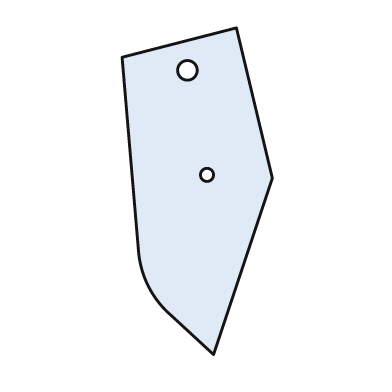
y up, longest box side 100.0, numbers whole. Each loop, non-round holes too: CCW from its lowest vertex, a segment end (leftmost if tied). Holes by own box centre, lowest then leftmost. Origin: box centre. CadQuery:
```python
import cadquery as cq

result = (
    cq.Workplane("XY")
    .moveTo(5.0, -50.0)
    .lineTo(23.0, 4.0)
    .lineTo(12.0, 50.0)
    .lineTo(-23.0, 41.0)
    .lineTo(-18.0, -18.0)
    .threePointArc((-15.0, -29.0), (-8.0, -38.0))
    .close()
    .moveTo(3.0, 5.0)
    .circle(2.0)
    .moveTo(-3.0, 37.0)
    .circle(3.0)
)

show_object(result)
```